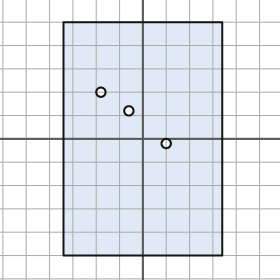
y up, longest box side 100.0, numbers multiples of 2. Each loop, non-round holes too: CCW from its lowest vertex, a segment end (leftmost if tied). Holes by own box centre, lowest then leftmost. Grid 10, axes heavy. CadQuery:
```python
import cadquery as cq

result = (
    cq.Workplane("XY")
    .moveTo(-34.0, -50.0)
    .lineTo(34.0, -50.0)
    .lineTo(34.0, 50.0)
    .lineTo(-34.0, 50.0)
    .close()
    .moveTo(10.0, -2.0)
    .circle(2.0)
    .moveTo(-6.0, 12.0)
    .circle(2.0)
    .moveTo(-18.0, 20.0)
    .circle(2.0)
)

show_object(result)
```